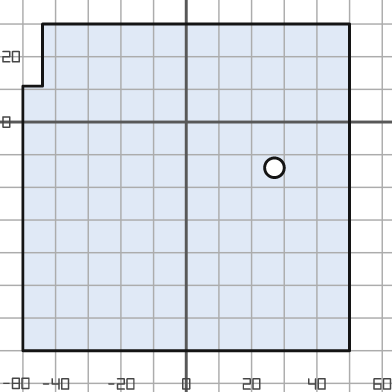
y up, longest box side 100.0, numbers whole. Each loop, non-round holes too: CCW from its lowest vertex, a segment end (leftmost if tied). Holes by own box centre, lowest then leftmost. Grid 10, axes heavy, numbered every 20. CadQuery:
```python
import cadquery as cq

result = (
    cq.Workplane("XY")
    .moveTo(-50.0, -70.0)
    .lineTo(50.0, -70.0)
    .lineTo(50.0, 30.0)
    .lineTo(-44.0, 30.0)
    .lineTo(-44.0, 11.0)
    .lineTo(-50.0, 11.0)
    .close()
    .moveTo(27.0, -14.0)
    .circle(3.0)
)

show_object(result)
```